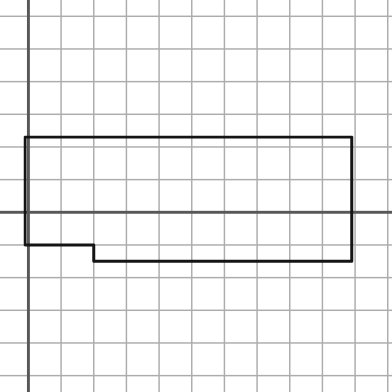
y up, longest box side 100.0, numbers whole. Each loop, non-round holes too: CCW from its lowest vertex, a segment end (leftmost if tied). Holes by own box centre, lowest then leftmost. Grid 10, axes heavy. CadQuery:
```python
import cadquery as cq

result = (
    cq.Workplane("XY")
    .moveTo(20.0, -15.0)
    .lineTo(99.0, -15.0)
    .lineTo(99.0, 23.0)
    .lineTo(-1.0, 23.0)
    .lineTo(-1.0, -10.0)
    .lineTo(20.0, -10.0)
    .close()
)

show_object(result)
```